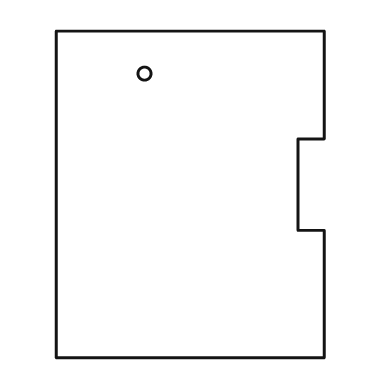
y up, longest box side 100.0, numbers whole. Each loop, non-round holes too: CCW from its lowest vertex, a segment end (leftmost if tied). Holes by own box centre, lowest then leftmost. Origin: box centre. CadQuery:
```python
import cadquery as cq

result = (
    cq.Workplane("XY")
    .moveTo(-41.0, -50.0)
    .lineTo(41.0, -50.0)
    .lineTo(41.0, -11.0)
    .lineTo(33.0, -11.0)
    .lineTo(33.0, 17.0)
    .lineTo(41.0, 17.0)
    .lineTo(41.0, 50.0)
    .lineTo(-41.0, 50.0)
    .close()
    .moveTo(-14.0, 37.0)
    .circle(2.0)
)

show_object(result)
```